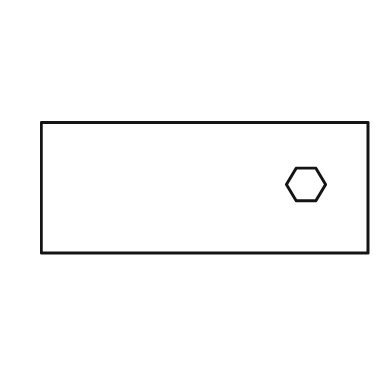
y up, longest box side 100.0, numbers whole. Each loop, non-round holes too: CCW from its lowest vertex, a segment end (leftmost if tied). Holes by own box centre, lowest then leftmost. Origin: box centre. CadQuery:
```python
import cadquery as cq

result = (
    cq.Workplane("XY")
    .moveTo(-50.0, -20.0)
    .lineTo(50.0, -20.0)
    .lineTo(50.0, 20.0)
    .lineTo(-50.0, 20.0)
    .close()
    .moveTo(28.0, -4.0)
    .lineTo(34.0, -4.0)
    .lineTo(37.0, 1.0)
    .lineTo(34.0, 6.0)
    .lineTo(28.0, 6.0)
    .lineTo(25.0, 1.0)
    .close()
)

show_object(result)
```